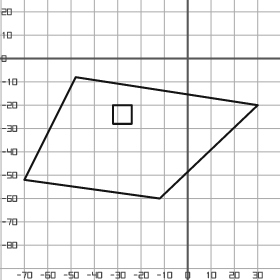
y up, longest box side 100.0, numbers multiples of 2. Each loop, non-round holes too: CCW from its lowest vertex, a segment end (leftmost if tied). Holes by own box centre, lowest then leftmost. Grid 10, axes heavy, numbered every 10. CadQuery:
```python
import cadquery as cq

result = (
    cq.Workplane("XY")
    .moveTo(-12.0, -60.0)
    .lineTo(30.0, -20.0)
    .lineTo(-48.0, -8.0)
    .lineTo(-70.0, -52.0)
    .close()
    .moveTo(-32.0, -28.0)
    .lineTo(-24.0, -28.0)
    .lineTo(-24.0, -20.0)
    .lineTo(-32.0, -20.0)
    .close()
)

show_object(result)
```